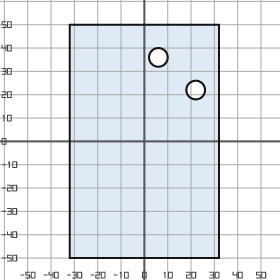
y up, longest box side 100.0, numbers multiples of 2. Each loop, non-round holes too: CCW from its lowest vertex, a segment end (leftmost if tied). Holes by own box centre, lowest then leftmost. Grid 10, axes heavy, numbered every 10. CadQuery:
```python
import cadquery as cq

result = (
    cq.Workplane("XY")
    .moveTo(-32.0, -50.0)
    .lineTo(32.0, -50.0)
    .lineTo(32.0, 50.0)
    .lineTo(-32.0, 50.0)
    .close()
    .moveTo(22.0, 22.0)
    .circle(4.0)
    .moveTo(6.0, 36.0)
    .circle(4.0)
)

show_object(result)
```